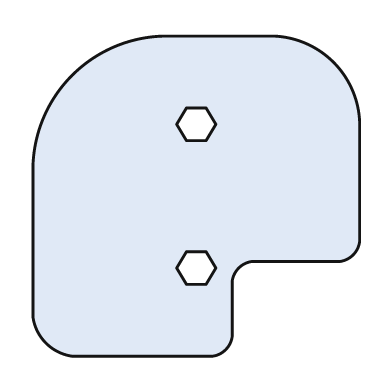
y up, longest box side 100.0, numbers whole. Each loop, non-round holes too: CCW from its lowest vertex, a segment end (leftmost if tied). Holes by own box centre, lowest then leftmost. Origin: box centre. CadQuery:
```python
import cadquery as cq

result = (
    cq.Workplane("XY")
    .moveTo(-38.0, -49.0)
    .lineTo(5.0, -49.0)
    .threePointArc((9.0, -47.0), (11.0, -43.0))
    .lineTo(11.0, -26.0)
    .threePointArc((13.0, -22.0), (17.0, -20.0))
    .lineTo(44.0, -20.0)
    .threePointArc((48.0, -18.0), (50.0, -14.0))
    .lineTo(50.0, 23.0)
    .threePointArc((42.0, 41.0), (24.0, 49.0))
    .lineTo(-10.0, 49.0)
    .threePointArc((-38.0, 37.0), (-50.0, 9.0))
    .lineTo(-50.0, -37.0)
    .threePointArc((-46.0, -45.0), (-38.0, -49.0))
    .close()
    .moveTo(-3.0, -27.0)
    .lineTo(3.0, -27.0)
    .lineTo(6.0, -22.0)
    .lineTo(3.0, -17.0)
    .lineTo(-3.0, -17.0)
    .lineTo(-6.0, -22.0)
    .close()
    .moveTo(-3.0, 17.0)
    .lineTo(3.0, 17.0)
    .lineTo(6.0, 22.0)
    .lineTo(3.0, 27.0)
    .lineTo(-3.0, 27.0)
    .lineTo(-6.0, 22.0)
    .close()
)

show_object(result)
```